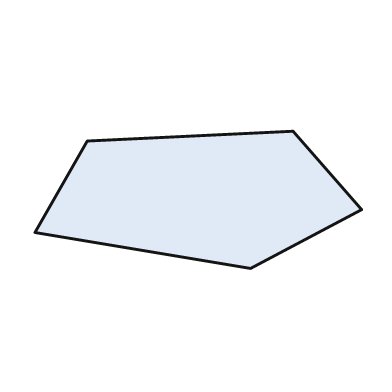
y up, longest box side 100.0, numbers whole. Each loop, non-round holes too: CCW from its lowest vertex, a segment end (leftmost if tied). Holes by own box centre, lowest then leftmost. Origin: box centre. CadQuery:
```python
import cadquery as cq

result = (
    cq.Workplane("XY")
    .moveTo(16.0, -21.0)
    .lineTo(50.0, -3.0)
    .lineTo(29.0, 21.0)
    .lineTo(-34.0, 18.0)
    .lineTo(-50.0, -10.0)
    .close()
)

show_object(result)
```